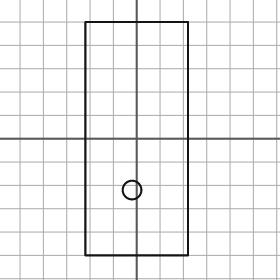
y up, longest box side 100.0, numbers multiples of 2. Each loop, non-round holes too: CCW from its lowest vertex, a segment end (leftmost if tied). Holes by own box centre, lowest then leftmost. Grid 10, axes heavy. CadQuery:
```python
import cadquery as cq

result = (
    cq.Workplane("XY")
    .moveTo(-22.0, -50.0)
    .lineTo(22.0, -50.0)
    .lineTo(22.0, 50.0)
    .lineTo(-22.0, 50.0)
    .close()
    .moveTo(-2.0, -22.0)
    .circle(4.0)
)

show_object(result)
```